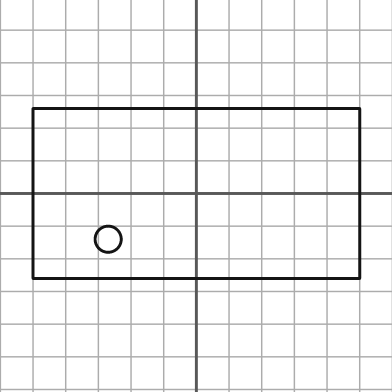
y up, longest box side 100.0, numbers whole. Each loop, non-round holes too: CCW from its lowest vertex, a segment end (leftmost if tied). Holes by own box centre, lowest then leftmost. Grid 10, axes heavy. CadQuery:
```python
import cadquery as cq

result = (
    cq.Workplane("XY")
    .moveTo(-50.0, -26.0)
    .lineTo(50.0, -26.0)
    .lineTo(50.0, 26.0)
    .lineTo(-50.0, 26.0)
    .close()
    .moveTo(-27.0, -14.0)
    .circle(4.0)
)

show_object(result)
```